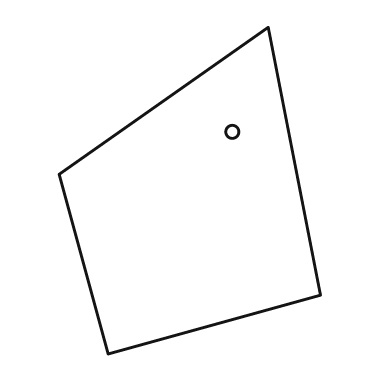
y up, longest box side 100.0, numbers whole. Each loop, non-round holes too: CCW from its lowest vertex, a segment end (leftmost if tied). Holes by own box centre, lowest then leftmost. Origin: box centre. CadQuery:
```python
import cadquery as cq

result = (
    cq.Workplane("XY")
    .moveTo(-25.0, -50.0)
    .lineTo(40.0, -32.0)
    .lineTo(24.0, 50.0)
    .lineTo(-40.0, 5.0)
    .close()
    .moveTo(13.0, 18.0)
    .circle(2.0)
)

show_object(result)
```